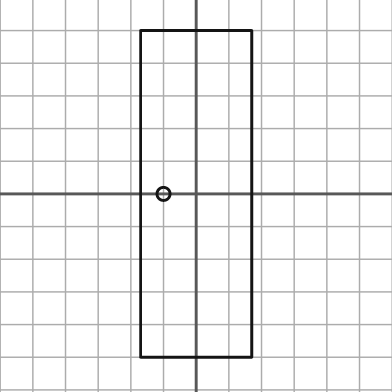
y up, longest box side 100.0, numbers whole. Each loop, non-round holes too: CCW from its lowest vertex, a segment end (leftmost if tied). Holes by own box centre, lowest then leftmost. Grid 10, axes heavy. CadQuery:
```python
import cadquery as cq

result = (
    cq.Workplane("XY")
    .moveTo(-17.0, -50.0)
    .lineTo(17.0, -50.0)
    .lineTo(17.0, 50.0)
    .lineTo(-17.0, 50.0)
    .close()
    .moveTo(-10.0, 0.0)
    .circle(2.0)
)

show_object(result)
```